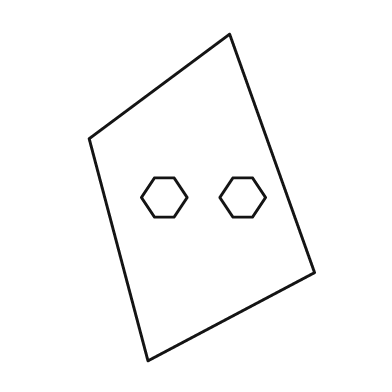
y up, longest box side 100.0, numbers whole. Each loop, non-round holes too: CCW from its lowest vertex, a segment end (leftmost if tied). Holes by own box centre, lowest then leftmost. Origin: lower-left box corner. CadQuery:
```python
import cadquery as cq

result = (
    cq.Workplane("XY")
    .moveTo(18.0, 0.0)
    .lineTo(69.0, 27.0)
    .lineTo(43.0, 100.0)
    .lineTo(0.0, 68.0)
    .close()
    .moveTo(20.0, 44.0)
    .lineTo(26.0, 44.0)
    .lineTo(30.0, 50.0)
    .lineTo(26.0, 56.0)
    .lineTo(20.0, 56.0)
    .lineTo(16.0, 50.0)
    .close()
    .moveTo(44.0, 44.0)
    .lineTo(50.0, 44.0)
    .lineTo(54.0, 50.0)
    .lineTo(50.0, 56.0)
    .lineTo(44.0, 56.0)
    .lineTo(40.0, 50.0)
    .close()
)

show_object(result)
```